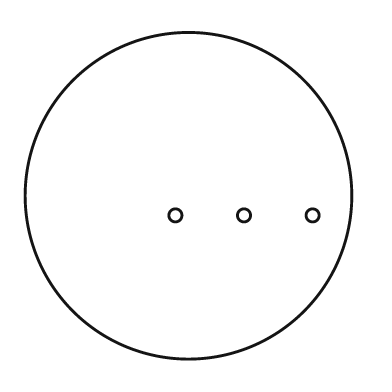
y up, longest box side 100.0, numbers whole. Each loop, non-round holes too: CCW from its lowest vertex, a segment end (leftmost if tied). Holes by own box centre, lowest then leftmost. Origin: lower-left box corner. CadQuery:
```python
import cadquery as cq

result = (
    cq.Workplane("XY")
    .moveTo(50.0, 50.0)
    .circle(50.0)
    .moveTo(46.0, 44.0)
    .circle(2.0)
    .moveTo(67.0, 44.0)
    .circle(2.0)
    .moveTo(88.0, 44.0)
    .circle(2.0)
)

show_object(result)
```